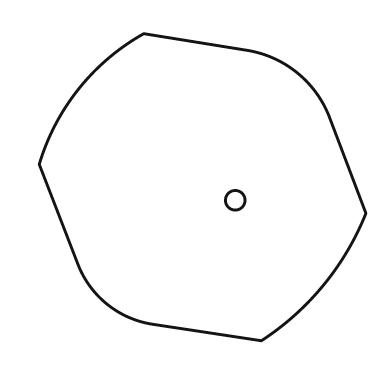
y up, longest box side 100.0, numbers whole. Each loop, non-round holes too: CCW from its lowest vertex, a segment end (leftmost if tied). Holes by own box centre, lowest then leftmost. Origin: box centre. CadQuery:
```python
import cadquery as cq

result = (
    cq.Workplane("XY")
    .moveTo(18.0, -47.0)
    .threePointArc((37.0, -30.0), (50.0, -8.0))
    .lineTo(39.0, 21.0)
    .threePointArc((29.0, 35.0), (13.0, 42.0))
    .lineTo(-18.0, 47.0)
    .threePointArc((-38.0, 30.0), (-50.0, 7.0))
    .lineTo(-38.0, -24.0)
    .threePointArc((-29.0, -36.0), (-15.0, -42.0))
    .close()
    .moveTo(10.0, -4.0)
    .circle(3.0)
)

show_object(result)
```